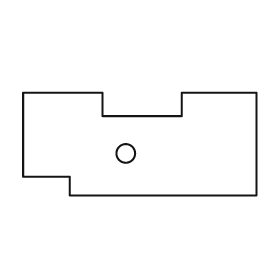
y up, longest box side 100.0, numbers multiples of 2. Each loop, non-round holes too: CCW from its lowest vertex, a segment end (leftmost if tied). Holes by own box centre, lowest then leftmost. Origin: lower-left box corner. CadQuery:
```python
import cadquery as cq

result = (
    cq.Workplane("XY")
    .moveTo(20.0, 0.0)
    .lineTo(100.0, 0.0)
    .lineTo(100.0, 44.0)
    .lineTo(68.0, 44.0)
    .lineTo(68.0, 34.0)
    .lineTo(34.0, 34.0)
    .lineTo(34.0, 44.0)
    .lineTo(0.0, 44.0)
    .lineTo(0.0, 8.0)
    .lineTo(20.0, 8.0)
    .close()
    .moveTo(44.0, 18.0)
    .circle(4.0)
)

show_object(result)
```